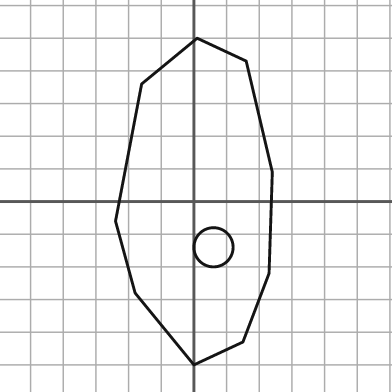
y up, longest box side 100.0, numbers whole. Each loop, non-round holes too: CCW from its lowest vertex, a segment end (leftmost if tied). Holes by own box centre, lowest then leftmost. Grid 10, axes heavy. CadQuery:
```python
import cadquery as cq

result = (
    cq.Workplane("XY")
    .moveTo(0.0, -50.0)
    .lineTo(15.0, -43.0)
    .lineTo(23.0, -22.0)
    .lineTo(24.0, 9.0)
    .lineTo(16.0, 43.0)
    .lineTo(1.0, 50.0)
    .lineTo(-16.0, 36.0)
    .lineTo(-24.0, -6.0)
    .lineTo(-18.0, -28.0)
    .close()
    .moveTo(6.0, -14.0)
    .circle(6.0)
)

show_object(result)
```